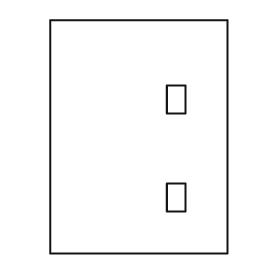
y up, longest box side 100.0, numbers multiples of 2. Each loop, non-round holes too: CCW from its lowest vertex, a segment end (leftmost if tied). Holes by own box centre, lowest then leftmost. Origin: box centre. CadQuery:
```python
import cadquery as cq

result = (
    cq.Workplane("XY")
    .moveTo(-38.0, -50.0)
    .lineTo(38.0, -50.0)
    .lineTo(38.0, 50.0)
    .lineTo(-38.0, 50.0)
    .close()
    .moveTo(12.0, -32.0)
    .lineTo(20.0, -32.0)
    .lineTo(20.0, -20.0)
    .lineTo(12.0, -20.0)
    .close()
    .moveTo(12.0, 10.0)
    .lineTo(20.0, 10.0)
    .lineTo(20.0, 22.0)
    .lineTo(12.0, 22.0)
    .close()
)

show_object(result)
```